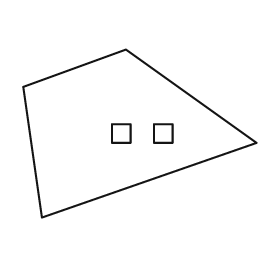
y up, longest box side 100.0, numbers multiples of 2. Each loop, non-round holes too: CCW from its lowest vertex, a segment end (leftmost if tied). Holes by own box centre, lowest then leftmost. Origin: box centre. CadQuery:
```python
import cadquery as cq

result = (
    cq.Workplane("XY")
    .moveTo(-42.0, -36.0)
    .lineTo(50.0, -4.0)
    .lineTo(-6.0, 36.0)
    .lineTo(-50.0, 20.0)
    .close()
    .moveTo(-12.0, -4.0)
    .lineTo(-4.0, -4.0)
    .lineTo(-4.0, 4.0)
    .lineTo(-12.0, 4.0)
    .close()
    .moveTo(6.0, -4.0)
    .lineTo(14.0, -4.0)
    .lineTo(14.0, 4.0)
    .lineTo(6.0, 4.0)
    .close()
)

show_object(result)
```